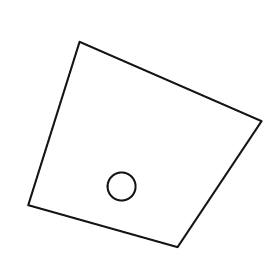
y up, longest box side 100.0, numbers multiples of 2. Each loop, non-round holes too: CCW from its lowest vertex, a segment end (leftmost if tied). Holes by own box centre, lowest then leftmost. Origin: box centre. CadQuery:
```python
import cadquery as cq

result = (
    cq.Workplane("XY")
    .moveTo(14.0, -44.0)
    .lineTo(50.0, 10.0)
    .lineTo(-28.0, 44.0)
    .lineTo(-50.0, -26.0)
    .close()
    .moveTo(-10.0, -18.0)
    .circle(6.0)
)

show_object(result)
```